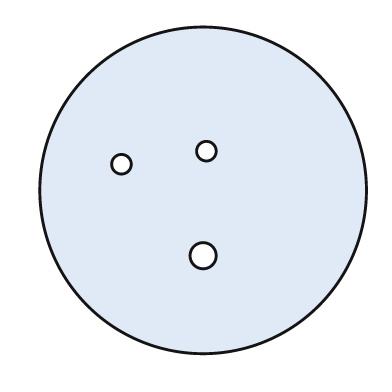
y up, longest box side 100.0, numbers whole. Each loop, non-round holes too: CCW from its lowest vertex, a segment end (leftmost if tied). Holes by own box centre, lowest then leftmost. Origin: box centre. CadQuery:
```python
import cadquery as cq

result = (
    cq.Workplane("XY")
    .moveTo(0.0, 0.0)
    .circle(50.0)
    .moveTo(0.0, -20.0)
    .circle(4.0)
    .moveTo(-25.0, 8.0)
    .circle(3.0)
    .moveTo(1.0, 12.0)
    .circle(3.0)
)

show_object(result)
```